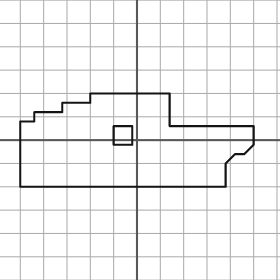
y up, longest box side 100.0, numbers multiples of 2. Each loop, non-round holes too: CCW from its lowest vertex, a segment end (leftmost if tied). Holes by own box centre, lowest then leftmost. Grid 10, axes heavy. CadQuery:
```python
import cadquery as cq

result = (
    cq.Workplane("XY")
    .moveTo(-50.0, -20.0)
    .lineTo(38.0, -20.0)
    .lineTo(38.0, -10.0)
    .lineTo(42.0, -6.0)
    .lineTo(46.0, -6.0)
    .lineTo(50.0, -2.0)
    .lineTo(50.0, 6.0)
    .lineTo(14.0, 6.0)
    .lineTo(14.0, 20.0)
    .lineTo(-20.0, 20.0)
    .lineTo(-20.0, 16.0)
    .lineTo(-32.0, 16.0)
    .lineTo(-32.0, 12.0)
    .lineTo(-44.0, 12.0)
    .lineTo(-44.0, 8.0)
    .lineTo(-50.0, 8.0)
    .close()
    .moveTo(-10.0, -2.0)
    .lineTo(-2.0, -2.0)
    .lineTo(-2.0, 6.0)
    .lineTo(-10.0, 6.0)
    .close()
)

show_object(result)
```